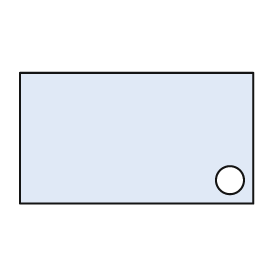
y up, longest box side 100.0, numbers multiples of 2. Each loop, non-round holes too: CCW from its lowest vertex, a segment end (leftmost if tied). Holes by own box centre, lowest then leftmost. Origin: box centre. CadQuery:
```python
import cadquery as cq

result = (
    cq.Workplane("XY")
    .moveTo(-50.0, -28.0)
    .lineTo(50.0, -28.0)
    .lineTo(50.0, 28.0)
    .lineTo(-50.0, 28.0)
    .close()
    .moveTo(40.0, -18.0)
    .circle(6.0)
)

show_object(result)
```